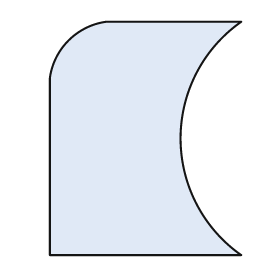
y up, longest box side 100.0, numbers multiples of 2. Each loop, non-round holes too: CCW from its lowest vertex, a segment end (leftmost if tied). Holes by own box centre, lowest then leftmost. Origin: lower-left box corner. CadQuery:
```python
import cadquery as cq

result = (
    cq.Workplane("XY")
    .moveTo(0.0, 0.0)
    .lineTo(82.0, 0.0)
    .threePointArc((56.0, 50.0), (82.0, 100.0))
    .lineTo(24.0, 100.0)
    .threePointArc((8.0, 92.0), (0.0, 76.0))
    .close()
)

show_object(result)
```